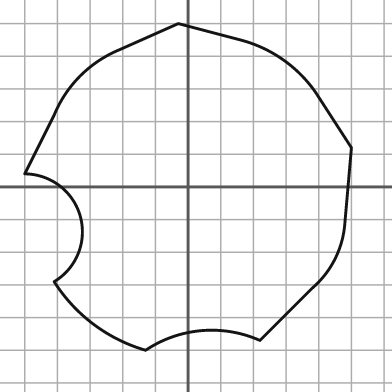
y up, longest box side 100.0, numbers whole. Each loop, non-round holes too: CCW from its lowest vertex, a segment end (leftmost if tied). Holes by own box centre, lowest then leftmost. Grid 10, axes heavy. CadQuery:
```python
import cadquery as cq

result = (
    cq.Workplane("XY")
    .moveTo(-13.0, -50.0)
    .threePointArc((4.0, -44.0), (22.0, -47.0))
    .lineTo(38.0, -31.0)
    .threePointArc((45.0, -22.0), (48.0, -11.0))
    .lineTo(50.0, 12.0)
    .lineTo(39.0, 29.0)
    .threePointArc((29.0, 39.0), (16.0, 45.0))
    .lineTo(-3.0, 50.0)
    .lineTo(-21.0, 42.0)
    .threePointArc((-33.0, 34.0), (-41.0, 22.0))
    .lineTo(-50.0, 4.0)
    .threePointArc((-33.0, -9.0), (-41.0, -29.0))
    .threePointArc((-29.0, -42.0), (-13.0, -50.0))
    .close()
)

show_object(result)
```